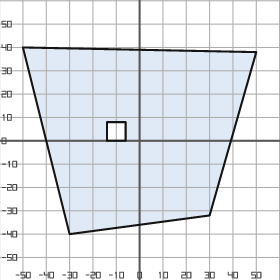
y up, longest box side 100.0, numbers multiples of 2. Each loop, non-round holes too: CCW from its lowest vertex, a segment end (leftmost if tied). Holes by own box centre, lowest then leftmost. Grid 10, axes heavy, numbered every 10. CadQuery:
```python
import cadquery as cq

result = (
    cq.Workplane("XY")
    .moveTo(-30.0, -40.0)
    .lineTo(30.0, -32.0)
    .lineTo(50.0, 38.0)
    .lineTo(-50.0, 40.0)
    .close()
    .moveTo(-14.0, 0.0)
    .lineTo(-6.0, 0.0)
    .lineTo(-6.0, 8.0)
    .lineTo(-14.0, 8.0)
    .close()
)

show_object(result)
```